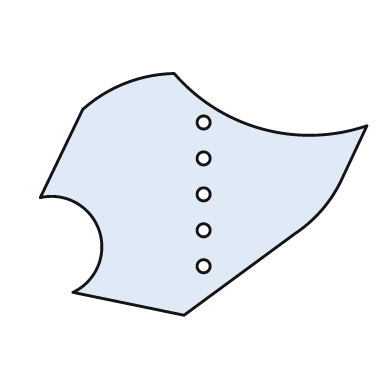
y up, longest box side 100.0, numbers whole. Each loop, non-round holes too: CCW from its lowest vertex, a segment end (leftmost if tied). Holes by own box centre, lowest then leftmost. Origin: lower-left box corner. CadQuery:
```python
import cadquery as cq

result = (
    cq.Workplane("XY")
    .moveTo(44.0, 0.0)
    .lineTo(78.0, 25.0)
    .threePointArc((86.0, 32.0), (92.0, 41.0))
    .lineTo(100.0, 58.0)
    .threePointArc((68.0, 57.0), (41.0, 74.0))
    .threePointArc((26.0, 71.0), (13.0, 63.0))
    .lineTo(0.0, 36.0)
    .threePointArc((18.0, 26.0), (10.0, 7.0))
    .close()
    .moveTo(50.0, 15.0)
    .circle(2.0)
    .moveTo(50.0, 26.0)
    .circle(2.0)
    .moveTo(50.0, 37.0)
    .circle(2.0)
    .moveTo(50.0, 48.0)
    .circle(2.0)
    .moveTo(50.0, 59.0)
    .circle(2.0)
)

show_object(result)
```